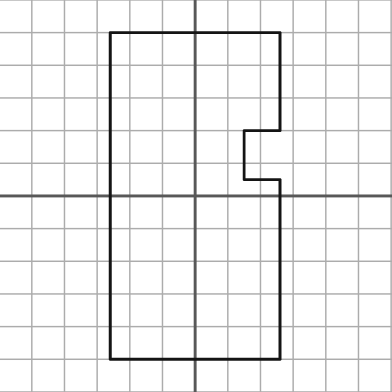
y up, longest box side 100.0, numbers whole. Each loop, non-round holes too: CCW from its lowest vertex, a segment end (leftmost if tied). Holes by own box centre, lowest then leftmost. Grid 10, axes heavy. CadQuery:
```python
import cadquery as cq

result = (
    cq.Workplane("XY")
    .moveTo(-26.0, -50.0)
    .lineTo(26.0, -50.0)
    .lineTo(26.0, 5.0)
    .lineTo(15.0, 5.0)
    .lineTo(15.0, 20.0)
    .lineTo(26.0, 20.0)
    .lineTo(26.0, 50.0)
    .lineTo(-26.0, 50.0)
    .close()
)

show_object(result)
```